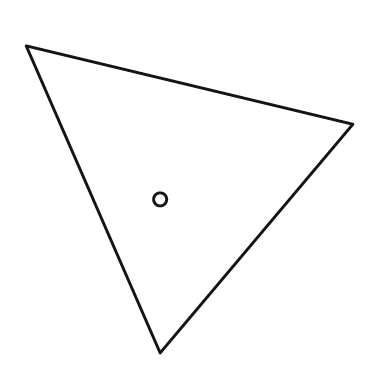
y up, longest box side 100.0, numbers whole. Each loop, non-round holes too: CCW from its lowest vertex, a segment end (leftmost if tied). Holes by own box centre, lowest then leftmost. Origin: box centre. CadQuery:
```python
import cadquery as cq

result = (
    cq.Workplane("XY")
    .moveTo(-9.0, -47.0)
    .lineTo(50.0, 23.0)
    .lineTo(-50.0, 47.0)
    .close()
    .moveTo(-9.0, 0.0)
    .circle(2.0)
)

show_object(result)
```